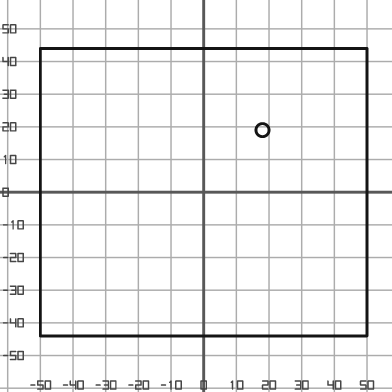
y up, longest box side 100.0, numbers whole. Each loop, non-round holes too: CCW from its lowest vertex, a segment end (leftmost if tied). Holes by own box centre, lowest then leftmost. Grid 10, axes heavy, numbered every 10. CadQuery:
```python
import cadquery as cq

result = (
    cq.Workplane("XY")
    .moveTo(-50.0, -44.0)
    .lineTo(50.0, -44.0)
    .lineTo(50.0, 44.0)
    .lineTo(-50.0, 44.0)
    .close()
    .moveTo(18.0, 19.0)
    .circle(2.0)
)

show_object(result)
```